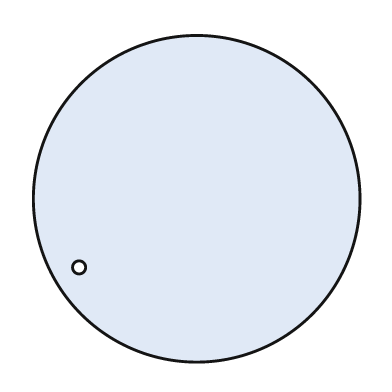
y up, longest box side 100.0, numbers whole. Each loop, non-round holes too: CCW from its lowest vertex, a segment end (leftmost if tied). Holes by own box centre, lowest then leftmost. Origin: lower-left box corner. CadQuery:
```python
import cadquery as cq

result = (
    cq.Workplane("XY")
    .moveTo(50.0, 50.0)
    .circle(50.0)
    .moveTo(14.0, 29.0)
    .circle(2.0)
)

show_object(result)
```